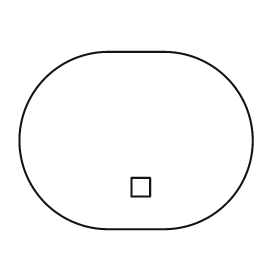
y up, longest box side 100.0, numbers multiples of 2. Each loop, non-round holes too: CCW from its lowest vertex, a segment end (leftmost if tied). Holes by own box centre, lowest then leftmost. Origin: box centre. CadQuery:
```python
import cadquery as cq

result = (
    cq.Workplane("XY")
    .moveTo(-12.0, -38.0)
    .lineTo(12.0, -38.0)
    .threePointArc((50.0, 0.0), (12.0, 38.0))
    .lineTo(-12.0, 38.0)
    .threePointArc((-50.0, 0.0), (-12.0, -38.0))
    .close()
    .moveTo(-2.0, -24.0)
    .lineTo(6.0, -24.0)
    .lineTo(6.0, -16.0)
    .lineTo(-2.0, -16.0)
    .close()
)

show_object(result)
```